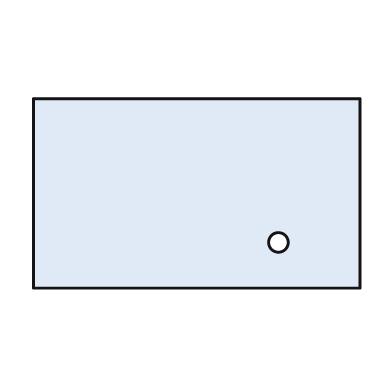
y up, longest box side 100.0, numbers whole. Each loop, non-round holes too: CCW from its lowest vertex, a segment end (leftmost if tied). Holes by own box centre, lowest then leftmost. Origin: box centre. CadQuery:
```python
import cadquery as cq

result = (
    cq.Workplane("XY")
    .moveTo(-50.0, -29.0)
    .lineTo(50.0, -29.0)
    .lineTo(50.0, 29.0)
    .lineTo(-50.0, 29.0)
    .close()
    .moveTo(25.0, -15.0)
    .circle(3.0)
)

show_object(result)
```